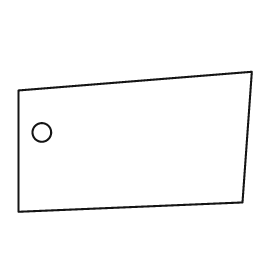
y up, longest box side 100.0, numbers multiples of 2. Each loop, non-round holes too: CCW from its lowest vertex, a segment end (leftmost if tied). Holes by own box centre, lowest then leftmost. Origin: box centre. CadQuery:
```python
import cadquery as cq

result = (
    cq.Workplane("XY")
    .moveTo(-50.0, -30.0)
    .lineTo(46.0, -26.0)
    .lineTo(50.0, 30.0)
    .lineTo(-50.0, 22.0)
    .close()
    .moveTo(-40.0, 4.0)
    .circle(4.0)
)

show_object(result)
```